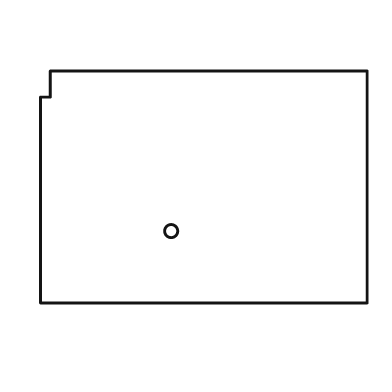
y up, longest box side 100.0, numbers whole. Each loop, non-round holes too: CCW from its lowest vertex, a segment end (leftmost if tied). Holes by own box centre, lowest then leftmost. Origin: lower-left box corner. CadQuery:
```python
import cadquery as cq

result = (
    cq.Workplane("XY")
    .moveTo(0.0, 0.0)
    .lineTo(100.0, 0.0)
    .lineTo(100.0, 71.0)
    .lineTo(3.0, 71.0)
    .lineTo(3.0, 63.0)
    .lineTo(0.0, 63.0)
    .close()
    .moveTo(40.0, 22.0)
    .circle(2.0)
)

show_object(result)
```